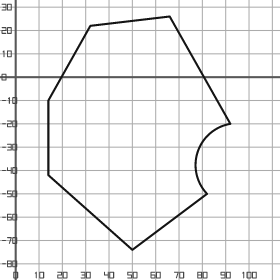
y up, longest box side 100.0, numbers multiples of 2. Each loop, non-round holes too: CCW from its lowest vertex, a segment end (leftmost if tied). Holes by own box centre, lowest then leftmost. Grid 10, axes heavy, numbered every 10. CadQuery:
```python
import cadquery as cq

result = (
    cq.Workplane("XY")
    .moveTo(50.0, -74.0)
    .lineTo(82.0, -50.0)
    .threePointArc((78.0, -32.0), (92.0, -20.0))
    .lineTo(66.0, 26.0)
    .lineTo(32.0, 22.0)
    .lineTo(14.0, -10.0)
    .lineTo(14.0, -42.0)
    .close()
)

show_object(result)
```